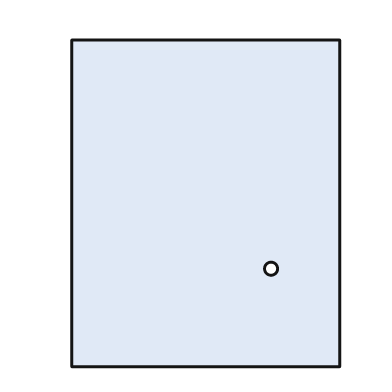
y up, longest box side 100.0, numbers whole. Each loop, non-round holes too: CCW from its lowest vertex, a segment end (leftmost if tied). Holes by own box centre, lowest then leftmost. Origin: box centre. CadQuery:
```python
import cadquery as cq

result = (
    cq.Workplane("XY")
    .moveTo(-41.0, -50.0)
    .lineTo(41.0, -50.0)
    .lineTo(41.0, 50.0)
    .lineTo(-41.0, 50.0)
    .close()
    .moveTo(20.0, -20.0)
    .circle(2.0)
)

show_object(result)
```